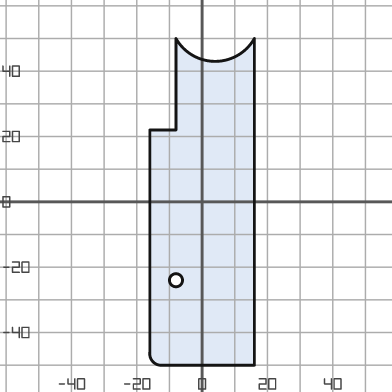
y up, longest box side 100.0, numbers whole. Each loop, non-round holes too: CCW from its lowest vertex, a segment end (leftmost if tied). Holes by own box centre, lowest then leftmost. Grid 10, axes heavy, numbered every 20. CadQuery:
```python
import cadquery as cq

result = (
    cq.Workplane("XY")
    .moveTo(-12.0, -50.0)
    .lineTo(16.0, -50.0)
    .lineTo(16.0, 50.0)
    .threePointArc((4.0, 43.0), (-8.0, 50.0))
    .lineTo(-8.0, 22.0)
    .lineTo(-16.0, 22.0)
    .lineTo(-16.0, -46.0)
    .threePointArc((-15.0, -49.0), (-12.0, -50.0))
    .close()
    .moveTo(-8.0, -24.0)
    .circle(2.0)
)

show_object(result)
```